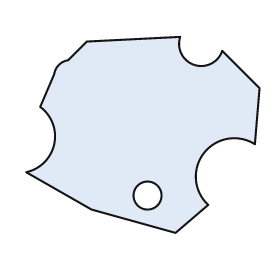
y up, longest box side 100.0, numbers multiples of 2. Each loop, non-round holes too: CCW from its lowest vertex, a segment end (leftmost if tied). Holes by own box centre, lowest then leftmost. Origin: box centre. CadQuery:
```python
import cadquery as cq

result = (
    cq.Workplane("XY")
    .moveTo(14.0, -42.0)
    .lineTo(28.0, -30.0)
    .threePointArc((26.0, -8.0), (48.0, -4.0))
    .lineTo(50.0, 20.0)
    .lineTo(34.0, 36.0)
    .threePointArc((22.0, 30.0), (16.0, 42.0))
    .lineTo(-24.0, 40.0)
    .lineTo(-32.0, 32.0)
    .threePointArc((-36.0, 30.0), (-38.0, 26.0))
    .lineTo(-44.0, 12.0)
    .threePointArc((-38.0, -4.0), (-50.0, -16.0))
    .lineTo(-22.0, -32.0)
    .close()
    .moveTo(2.0, -26.0)
    .circle(6.0)
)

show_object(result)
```